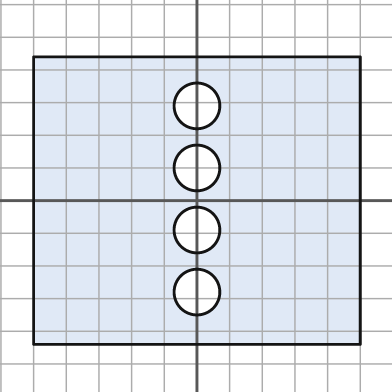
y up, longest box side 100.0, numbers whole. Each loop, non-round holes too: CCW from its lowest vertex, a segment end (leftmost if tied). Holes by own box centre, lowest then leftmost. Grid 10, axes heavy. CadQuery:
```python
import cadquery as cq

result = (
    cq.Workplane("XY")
    .moveTo(-50.0, -44.0)
    .lineTo(50.0, -44.0)
    .lineTo(50.0, 44.0)
    .lineTo(-50.0, 44.0)
    .close()
    .moveTo(0.0, -28.0)
    .circle(7.0)
    .moveTo(0.0, -9.0)
    .circle(7.0)
    .moveTo(0.0, 10.0)
    .circle(7.0)
    .moveTo(0.0, 29.0)
    .circle(7.0)
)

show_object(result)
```